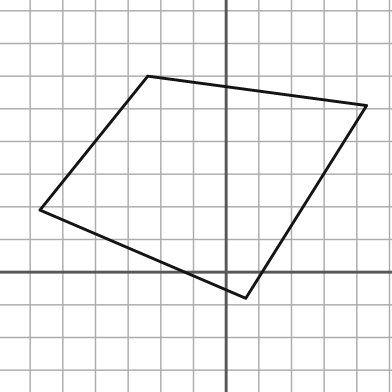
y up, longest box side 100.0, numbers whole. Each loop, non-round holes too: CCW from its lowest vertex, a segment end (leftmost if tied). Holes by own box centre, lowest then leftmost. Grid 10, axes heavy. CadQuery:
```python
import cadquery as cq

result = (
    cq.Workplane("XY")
    .moveTo(6.0, -8.0)
    .lineTo(43.0, 51.0)
    .lineTo(-24.0, 60.0)
    .lineTo(-57.0, 19.0)
    .close()
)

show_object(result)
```